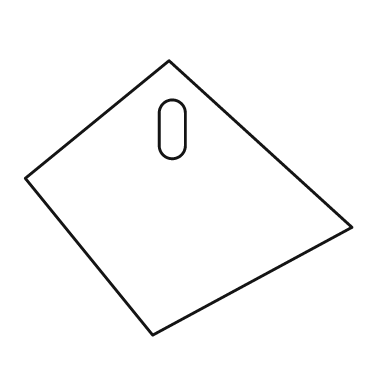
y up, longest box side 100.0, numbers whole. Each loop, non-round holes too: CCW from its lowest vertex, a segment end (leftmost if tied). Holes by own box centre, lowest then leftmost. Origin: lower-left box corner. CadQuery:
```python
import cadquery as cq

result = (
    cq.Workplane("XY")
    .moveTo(39.0, 0.0)
    .lineTo(100.0, 33.0)
    .lineTo(44.0, 84.0)
    .lineTo(0.0, 48.0)
    .close()
    .moveTo(41.0, 58.0)
    .threePointArc((45.0, 54.0), (49.0, 58.0))
    .lineTo(49.0, 68.0)
    .threePointArc((45.0, 72.0), (41.0, 68.0))
    .close()
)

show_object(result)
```